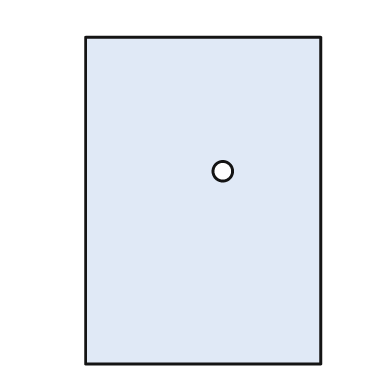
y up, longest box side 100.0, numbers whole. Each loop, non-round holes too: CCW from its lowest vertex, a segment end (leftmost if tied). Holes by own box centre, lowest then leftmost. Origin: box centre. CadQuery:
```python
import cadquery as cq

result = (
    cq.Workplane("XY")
    .moveTo(-36.0, -50.0)
    .lineTo(36.0, -50.0)
    .lineTo(36.0, 50.0)
    .lineTo(-36.0, 50.0)
    .close()
    .moveTo(6.0, 9.0)
    .circle(3.0)
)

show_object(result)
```